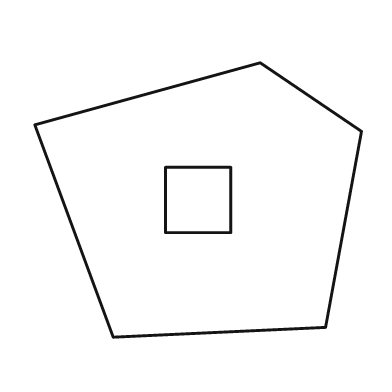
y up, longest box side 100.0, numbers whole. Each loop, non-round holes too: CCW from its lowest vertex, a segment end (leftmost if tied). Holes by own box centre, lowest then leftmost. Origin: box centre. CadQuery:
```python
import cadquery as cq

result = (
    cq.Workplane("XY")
    .moveTo(-26.0, -42.0)
    .lineTo(39.0, -39.0)
    .lineTo(50.0, 21.0)
    .lineTo(19.0, 42.0)
    .lineTo(-50.0, 23.0)
    .close()
    .moveTo(-10.0, -10.0)
    .lineTo(10.0, -10.0)
    .lineTo(10.0, 10.0)
    .lineTo(-10.0, 10.0)
    .close()
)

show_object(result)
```